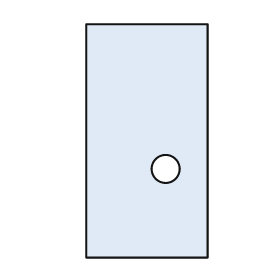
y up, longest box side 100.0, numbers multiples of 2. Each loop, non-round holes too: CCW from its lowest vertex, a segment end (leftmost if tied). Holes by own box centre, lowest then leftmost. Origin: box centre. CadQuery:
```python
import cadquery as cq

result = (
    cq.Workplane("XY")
    .moveTo(-26.0, -50.0)
    .lineTo(26.0, -50.0)
    .lineTo(26.0, 50.0)
    .lineTo(-26.0, 50.0)
    .close()
    .moveTo(8.0, -12.0)
    .circle(6.0)
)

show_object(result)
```